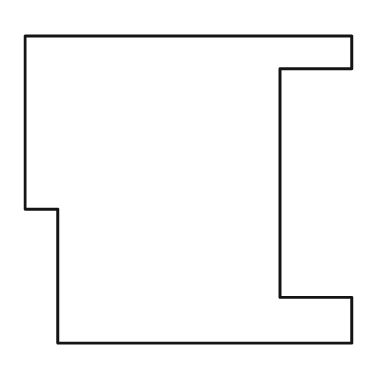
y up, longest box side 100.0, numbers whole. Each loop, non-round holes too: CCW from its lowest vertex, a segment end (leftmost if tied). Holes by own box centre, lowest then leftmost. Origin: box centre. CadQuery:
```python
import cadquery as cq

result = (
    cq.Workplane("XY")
    .moveTo(-40.0, -47.0)
    .lineTo(50.0, -47.0)
    .lineTo(50.0, -33.0)
    .lineTo(28.0, -33.0)
    .lineTo(28.0, 37.0)
    .lineTo(50.0, 37.0)
    .lineTo(50.0, 47.0)
    .lineTo(-50.0, 47.0)
    .lineTo(-50.0, -6.0)
    .lineTo(-40.0, -6.0)
    .close()
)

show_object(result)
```